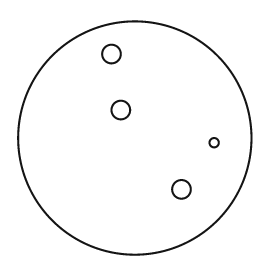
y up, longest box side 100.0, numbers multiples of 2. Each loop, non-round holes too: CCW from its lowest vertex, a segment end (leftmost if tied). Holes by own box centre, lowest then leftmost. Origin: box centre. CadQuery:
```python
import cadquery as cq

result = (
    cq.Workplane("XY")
    .moveTo(0.0, 0.0)
    .circle(50.0)
    .moveTo(20.0, -22.0)
    .circle(4.0)
    .moveTo(34.0, -2.0)
    .circle(2.0)
    .moveTo(-6.0, 12.0)
    .circle(4.0)
    .moveTo(-10.0, 36.0)
    .circle(4.0)
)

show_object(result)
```